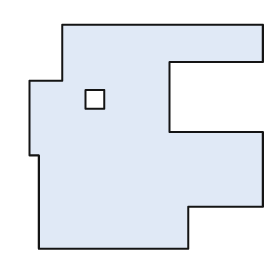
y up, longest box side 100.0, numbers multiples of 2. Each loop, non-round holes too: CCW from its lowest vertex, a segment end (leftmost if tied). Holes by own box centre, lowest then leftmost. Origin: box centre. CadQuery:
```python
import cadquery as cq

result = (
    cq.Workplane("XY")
    .moveTo(-46.0, -48.0)
    .lineTo(18.0, -48.0)
    .lineTo(18.0, -30.0)
    .lineTo(50.0, -30.0)
    .lineTo(50.0, 2.0)
    .lineTo(10.0, 2.0)
    .lineTo(10.0, 32.0)
    .lineTo(50.0, 32.0)
    .lineTo(50.0, 48.0)
    .lineTo(-36.0, 48.0)
    .lineTo(-36.0, 24.0)
    .lineTo(-50.0, 24.0)
    .lineTo(-50.0, -8.0)
    .lineTo(-46.0, -8.0)
    .close()
    .moveTo(-26.0, 12.0)
    .lineTo(-18.0, 12.0)
    .lineTo(-18.0, 20.0)
    .lineTo(-26.0, 20.0)
    .close()
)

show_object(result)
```